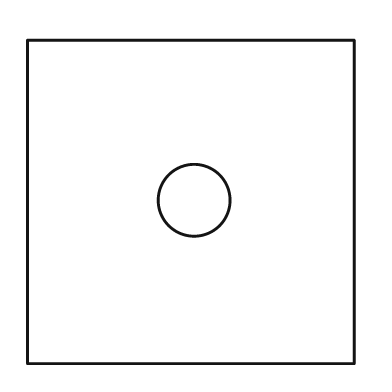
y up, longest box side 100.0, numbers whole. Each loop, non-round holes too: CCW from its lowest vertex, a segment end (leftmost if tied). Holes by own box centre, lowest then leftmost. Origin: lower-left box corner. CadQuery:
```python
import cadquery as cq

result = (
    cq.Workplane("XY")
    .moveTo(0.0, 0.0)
    .lineTo(100.0, 0.0)
    .lineTo(100.0, 99.0)
    .lineTo(0.0, 99.0)
    .close()
    .moveTo(51.0, 50.0)
    .circle(11.0)
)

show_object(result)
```